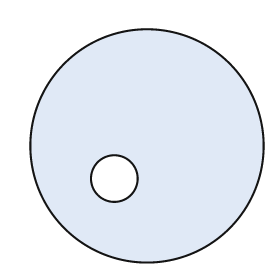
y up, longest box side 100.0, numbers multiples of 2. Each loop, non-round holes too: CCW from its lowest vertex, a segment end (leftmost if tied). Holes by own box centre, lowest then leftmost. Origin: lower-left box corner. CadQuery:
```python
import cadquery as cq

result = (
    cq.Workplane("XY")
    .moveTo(50.0, 50.0)
    .circle(50.0)
    .moveTo(36.0, 36.0)
    .circle(10.0)
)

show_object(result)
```